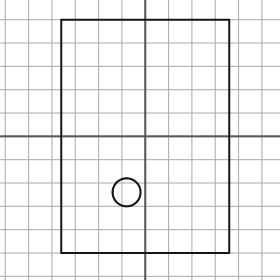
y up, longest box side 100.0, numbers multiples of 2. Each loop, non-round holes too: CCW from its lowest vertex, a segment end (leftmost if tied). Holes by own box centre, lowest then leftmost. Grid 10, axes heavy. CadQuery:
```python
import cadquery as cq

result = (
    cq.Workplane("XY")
    .moveTo(-36.0, -50.0)
    .lineTo(36.0, -50.0)
    .lineTo(36.0, 50.0)
    .lineTo(-36.0, 50.0)
    .close()
    .moveTo(-8.0, -24.0)
    .circle(6.0)
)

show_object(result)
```